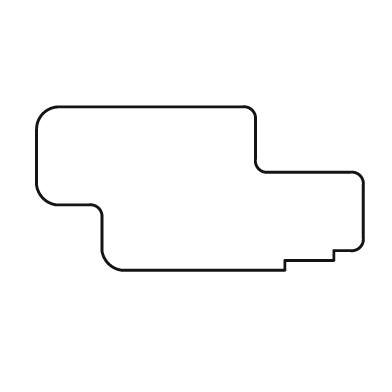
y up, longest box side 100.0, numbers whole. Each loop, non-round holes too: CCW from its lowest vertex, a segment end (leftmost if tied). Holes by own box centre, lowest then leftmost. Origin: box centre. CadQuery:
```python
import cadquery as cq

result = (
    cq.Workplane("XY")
    .moveTo(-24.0, -25.0)
    .lineTo(26.0, -25.0)
    .lineTo(26.0, -22.0)
    .lineTo(41.0, -22.0)
    .lineTo(41.0, -19.0)
    .lineTo(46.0, -19.0)
    .threePointArc((49.0, -18.0), (50.0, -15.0))
    .lineTo(50.0, 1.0)
    .threePointArc((49.0, 4.0), (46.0, 5.0))
    .lineTo(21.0, 5.0)
    .threePointArc((18.0, 6.0), (17.0, 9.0))
    .lineTo(17.0, 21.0)
    .threePointArc((16.0, 24.0), (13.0, 25.0))
    .lineTo(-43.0, 25.0)
    .threePointArc((-48.0, 23.0), (-50.0, 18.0))
    .lineTo(-50.0, 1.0)
    .threePointArc((-48.0, -3.0), (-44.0, -5.0))
    .lineTo(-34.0, -5.0)
    .threePointArc((-31.0, -6.0), (-30.0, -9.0))
    .lineTo(-30.0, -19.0)
    .threePointArc((-28.0, -23.0), (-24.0, -25.0))
    .close()
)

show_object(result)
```